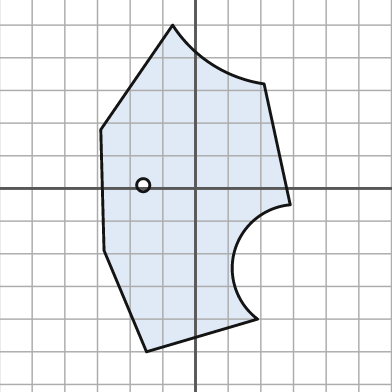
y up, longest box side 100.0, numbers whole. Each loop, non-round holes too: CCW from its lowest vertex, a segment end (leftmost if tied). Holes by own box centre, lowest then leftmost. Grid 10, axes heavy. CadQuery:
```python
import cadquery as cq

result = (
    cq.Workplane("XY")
    .moveTo(-15.0, -50.0)
    .lineTo(19.0, -40.0)
    .threePointArc((12.0, -19.0), (29.0, -5.0))
    .lineTo(21.0, 32.0)
    .threePointArc((5.0, 38.0), (-7.0, 50.0))
    .lineTo(-29.0, 18.0)
    .lineTo(-28.0, -19.0)
    .close()
    .moveTo(-16.0, 1.0)
    .circle(2.0)
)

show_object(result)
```